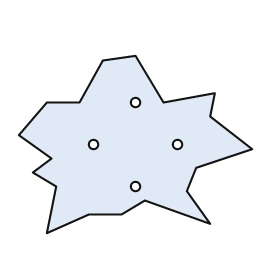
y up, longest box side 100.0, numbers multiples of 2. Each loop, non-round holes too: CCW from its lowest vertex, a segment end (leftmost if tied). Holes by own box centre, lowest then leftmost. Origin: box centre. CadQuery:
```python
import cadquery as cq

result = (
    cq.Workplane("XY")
    .moveTo(-38.0, -38.0)
    .lineTo(-20.0, -30.0)
    .lineTo(-6.0, -30.0)
    .lineTo(4.0, -24.0)
    .lineTo(32.0, -34.0)
    .lineTo(22.0, -20.0)
    .lineTo(26.0, -10.0)
    .lineTo(50.0, -2.0)
    .lineTo(32.0, 12.0)
    .lineTo(34.0, 22.0)
    .lineTo(12.0, 18.0)
    .lineTo(0.0, 38.0)
    .lineTo(-14.0, 36.0)
    .lineTo(-24.0, 18.0)
    .lineTo(-38.0, 18.0)
    .lineTo(-50.0, 4.0)
    .lineTo(-36.0, -6.0)
    .lineTo(-44.0, -12.0)
    .lineTo(-34.0, -18.0)
    .close()
    .moveTo(0.0, -18.0)
    .circle(2.0)
    .moveTo(-18.0, 0.0)
    .circle(2.0)
    .moveTo(18.0, 0.0)
    .circle(2.0)
    .moveTo(0.0, 18.0)
    .circle(2.0)
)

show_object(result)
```